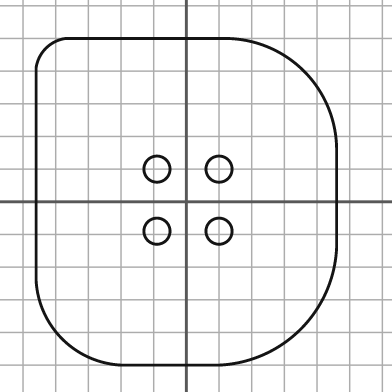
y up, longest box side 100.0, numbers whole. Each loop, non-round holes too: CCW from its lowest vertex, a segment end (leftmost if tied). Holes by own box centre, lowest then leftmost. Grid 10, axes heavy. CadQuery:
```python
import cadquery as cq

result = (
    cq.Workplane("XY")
    .moveTo(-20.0, -50.0)
    .lineTo(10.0, -50.0)
    .threePointArc((35.0, -39.0), (46.0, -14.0))
    .lineTo(46.0, 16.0)
    .threePointArc((36.0, 40.0), (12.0, 50.0))
    .lineTo(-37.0, 50.0)
    .threePointArc((-43.0, 47.0), (-46.0, 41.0))
    .lineTo(-46.0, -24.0)
    .threePointArc((-38.0, -42.0), (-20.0, -50.0))
    .close()
    .moveTo(-9.0, -9.0)
    .circle(4.0)
    .moveTo(10.0, -9.0)
    .circle(4.0)
    .moveTo(-9.0, 10.0)
    .circle(4.0)
    .moveTo(10.0, 10.0)
    .circle(4.0)
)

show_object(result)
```